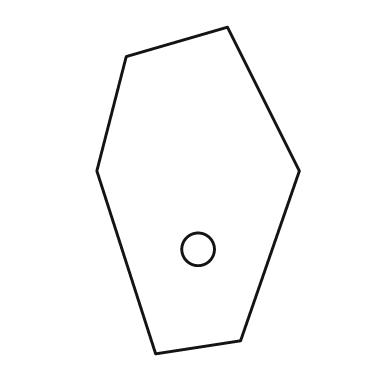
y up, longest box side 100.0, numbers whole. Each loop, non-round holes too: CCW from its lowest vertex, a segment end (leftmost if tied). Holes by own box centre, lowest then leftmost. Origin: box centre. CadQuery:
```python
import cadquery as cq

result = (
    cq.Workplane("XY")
    .moveTo(-13.0, -50.0)
    .lineTo(13.0, -46.0)
    .lineTo(31.0, 6.0)
    .lineTo(9.0, 50.0)
    .lineTo(-22.0, 41.0)
    .lineTo(-31.0, 6.0)
    .close()
    .moveTo(0.0, -18.0)
    .circle(5.0)
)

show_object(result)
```